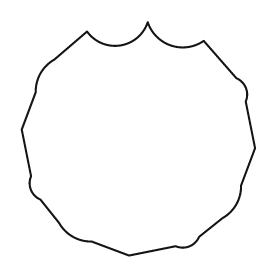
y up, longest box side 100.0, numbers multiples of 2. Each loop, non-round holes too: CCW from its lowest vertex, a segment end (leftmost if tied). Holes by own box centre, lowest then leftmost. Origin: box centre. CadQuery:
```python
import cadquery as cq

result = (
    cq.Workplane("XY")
    .moveTo(-4.0, -50.0)
    .lineTo(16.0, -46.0)
    .threePointArc((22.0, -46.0), (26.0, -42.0))
    .lineTo(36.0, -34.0)
    .threePointArc((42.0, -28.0), (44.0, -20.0))
    .lineTo(50.0, -4.0)
    .lineTo(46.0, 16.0)
    .threePointArc((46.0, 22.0), (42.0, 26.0))
    .lineTo(28.0, 42.0)
    .threePointArc((14.0, 40.0), (4.0, 50.0))
    .threePointArc((-8.0, 40.0), (-22.0, 46.0))
    .lineTo(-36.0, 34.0)
    .threePointArc((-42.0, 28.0), (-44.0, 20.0))
    .lineTo(-50.0, 4.0)
    .lineTo(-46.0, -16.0)
    .threePointArc((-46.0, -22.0), (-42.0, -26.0))
    .lineTo(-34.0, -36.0)
    .threePointArc((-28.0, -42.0), (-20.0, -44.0))
    .close()
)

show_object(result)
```